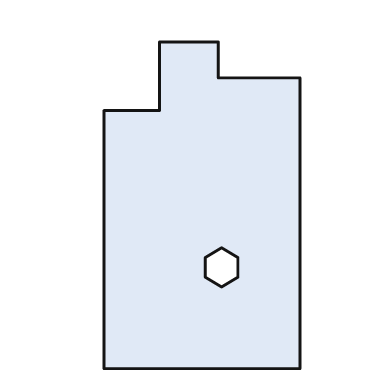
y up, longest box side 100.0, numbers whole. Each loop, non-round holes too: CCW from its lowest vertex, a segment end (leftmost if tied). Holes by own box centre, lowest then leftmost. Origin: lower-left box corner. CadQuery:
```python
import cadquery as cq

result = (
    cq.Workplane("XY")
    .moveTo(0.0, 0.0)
    .lineTo(60.0, 0.0)
    .lineTo(60.0, 89.0)
    .lineTo(35.0, 89.0)
    .lineTo(35.0, 100.0)
    .lineTo(17.0, 100.0)
    .lineTo(17.0, 79.0)
    .lineTo(0.0, 79.0)
    .close()
    .moveTo(36.0, 25.0)
    .lineTo(41.0, 28.0)
    .lineTo(41.0, 34.0)
    .lineTo(36.0, 37.0)
    .lineTo(31.0, 34.0)
    .lineTo(31.0, 28.0)
    .close()
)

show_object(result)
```